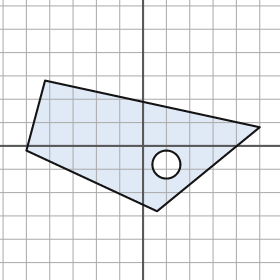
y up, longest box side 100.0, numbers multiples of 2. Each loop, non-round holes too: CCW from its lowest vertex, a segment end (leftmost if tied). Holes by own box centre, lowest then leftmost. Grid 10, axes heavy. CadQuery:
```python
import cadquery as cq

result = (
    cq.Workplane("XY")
    .moveTo(6.0, -28.0)
    .lineTo(50.0, 8.0)
    .lineTo(-42.0, 28.0)
    .lineTo(-50.0, -2.0)
    .close()
    .moveTo(10.0, -8.0)
    .circle(6.0)
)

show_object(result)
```